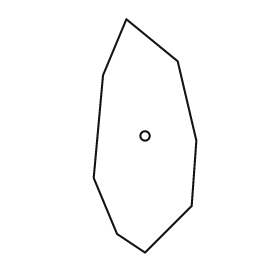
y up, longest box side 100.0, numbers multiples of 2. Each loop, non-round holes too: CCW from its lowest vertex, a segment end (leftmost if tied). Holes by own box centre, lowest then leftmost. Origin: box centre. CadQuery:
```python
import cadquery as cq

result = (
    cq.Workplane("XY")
    .moveTo(0.0, -50.0)
    .lineTo(20.0, -30.0)
    .lineTo(22.0, -2.0)
    .lineTo(14.0, 32.0)
    .lineTo(-8.0, 50.0)
    .lineTo(-18.0, 26.0)
    .lineTo(-22.0, -18.0)
    .lineTo(-12.0, -42.0)
    .close()
    .moveTo(0.0, 0.0)
    .circle(2.0)
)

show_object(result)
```